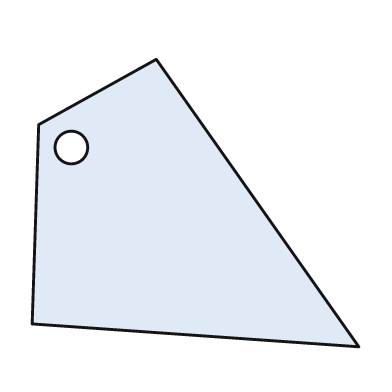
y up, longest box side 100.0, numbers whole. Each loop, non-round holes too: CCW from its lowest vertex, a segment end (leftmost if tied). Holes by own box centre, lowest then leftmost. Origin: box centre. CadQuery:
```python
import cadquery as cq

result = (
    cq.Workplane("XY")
    .moveTo(50.0, -44.0)
    .lineTo(-12.0, 44.0)
    .lineTo(-48.0, 24.0)
    .lineTo(-50.0, -37.0)
    .close()
    .moveTo(-38.0, 17.0)
    .circle(5.0)
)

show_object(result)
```